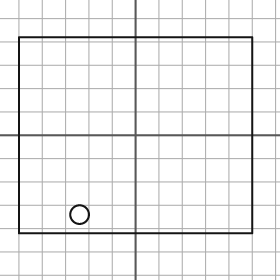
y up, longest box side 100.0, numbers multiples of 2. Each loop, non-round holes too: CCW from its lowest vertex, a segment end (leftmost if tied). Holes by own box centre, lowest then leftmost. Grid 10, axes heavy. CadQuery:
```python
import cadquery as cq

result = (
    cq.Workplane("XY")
    .moveTo(-50.0, -42.0)
    .lineTo(50.0, -42.0)
    .lineTo(50.0, 42.0)
    .lineTo(-50.0, 42.0)
    .close()
    .moveTo(-24.0, -34.0)
    .circle(4.0)
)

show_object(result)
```